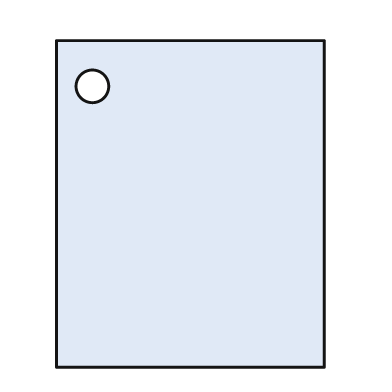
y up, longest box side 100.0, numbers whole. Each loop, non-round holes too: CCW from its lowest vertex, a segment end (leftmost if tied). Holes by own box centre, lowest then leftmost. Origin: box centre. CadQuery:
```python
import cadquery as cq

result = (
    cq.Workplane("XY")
    .moveTo(-41.0, -50.0)
    .lineTo(41.0, -50.0)
    .lineTo(41.0, 50.0)
    .lineTo(-41.0, 50.0)
    .close()
    .moveTo(-30.0, 36.0)
    .circle(5.0)
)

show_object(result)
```